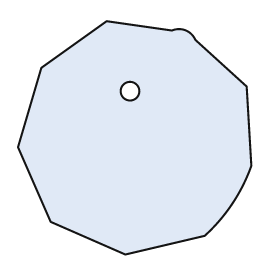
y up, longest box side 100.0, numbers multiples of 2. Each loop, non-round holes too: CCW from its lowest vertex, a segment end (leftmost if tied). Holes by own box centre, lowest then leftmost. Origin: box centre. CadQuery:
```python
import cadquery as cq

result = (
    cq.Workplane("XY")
    .moveTo(-4.0, -50.0)
    .lineTo(30.0, -42.0)
    .threePointArc((42.0, -28.0), (50.0, -12.0))
    .lineTo(48.0, 22.0)
    .lineTo(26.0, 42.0)
    .threePointArc((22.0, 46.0), (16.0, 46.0))
    .lineTo(-12.0, 50.0)
    .lineTo(-40.0, 30.0)
    .lineTo(-50.0, -4.0)
    .lineTo(-36.0, -36.0)
    .close()
    .moveTo(-2.0, 20.0)
    .circle(4.0)
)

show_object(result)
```